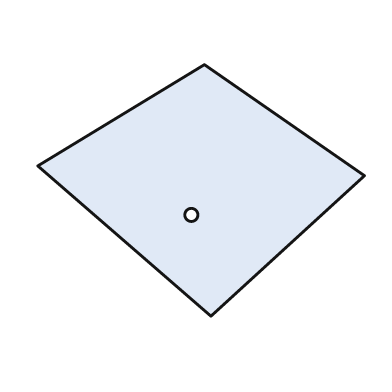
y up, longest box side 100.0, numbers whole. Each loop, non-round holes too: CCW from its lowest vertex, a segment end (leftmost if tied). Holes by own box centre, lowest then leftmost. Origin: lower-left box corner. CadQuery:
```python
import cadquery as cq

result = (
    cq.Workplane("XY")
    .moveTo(53.0, 0.0)
    .lineTo(100.0, 43.0)
    .lineTo(51.0, 77.0)
    .lineTo(0.0, 46.0)
    .close()
    .moveTo(47.0, 31.0)
    .circle(2.0)
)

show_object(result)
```